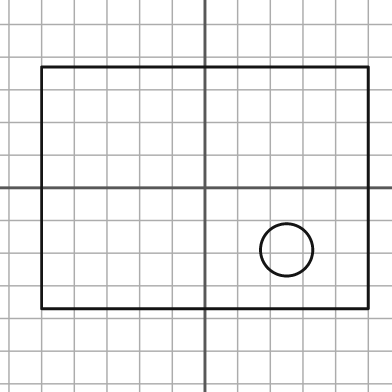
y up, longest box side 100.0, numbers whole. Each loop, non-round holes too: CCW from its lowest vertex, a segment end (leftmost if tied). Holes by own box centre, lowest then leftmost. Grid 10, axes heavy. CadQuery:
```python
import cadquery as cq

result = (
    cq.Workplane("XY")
    .moveTo(-50.0, -37.0)
    .lineTo(50.0, -37.0)
    .lineTo(50.0, 37.0)
    .lineTo(-50.0, 37.0)
    .close()
    .moveTo(25.0, -19.0)
    .circle(8.0)
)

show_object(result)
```